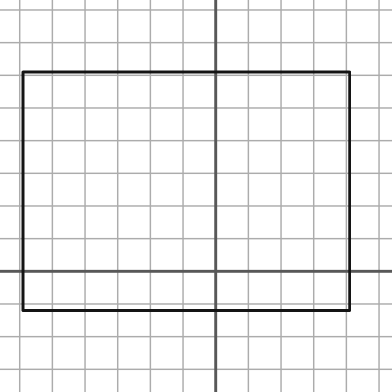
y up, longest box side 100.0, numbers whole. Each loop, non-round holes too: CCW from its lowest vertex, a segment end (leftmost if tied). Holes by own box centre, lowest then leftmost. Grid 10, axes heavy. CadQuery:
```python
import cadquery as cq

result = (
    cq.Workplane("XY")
    .moveTo(-59.0, -12.0)
    .lineTo(41.0, -12.0)
    .lineTo(41.0, 61.0)
    .lineTo(-59.0, 61.0)
    .close()
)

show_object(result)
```